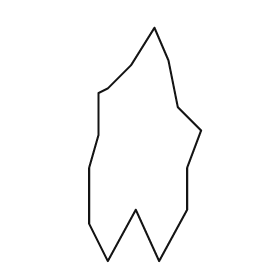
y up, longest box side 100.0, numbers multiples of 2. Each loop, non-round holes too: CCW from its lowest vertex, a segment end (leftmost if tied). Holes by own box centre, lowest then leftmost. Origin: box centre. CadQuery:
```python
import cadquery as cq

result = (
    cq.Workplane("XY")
    .moveTo(-16.0, -50.0)
    .lineTo(-4.0, -28.0)
    .lineTo(6.0, -50.0)
    .lineTo(18.0, -28.0)
    .lineTo(18.0, -10.0)
    .lineTo(24.0, 6.0)
    .lineTo(14.0, 16.0)
    .lineTo(10.0, 36.0)
    .lineTo(4.0, 50.0)
    .lineTo(-6.0, 34.0)
    .lineTo(-16.0, 24.0)
    .lineTo(-20.0, 22.0)
    .lineTo(-20.0, 4.0)
    .lineTo(-24.0, -10.0)
    .lineTo(-24.0, -34.0)
    .close()
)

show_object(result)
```